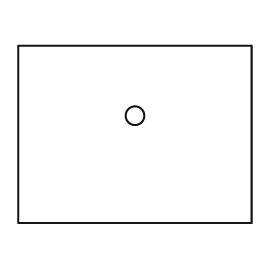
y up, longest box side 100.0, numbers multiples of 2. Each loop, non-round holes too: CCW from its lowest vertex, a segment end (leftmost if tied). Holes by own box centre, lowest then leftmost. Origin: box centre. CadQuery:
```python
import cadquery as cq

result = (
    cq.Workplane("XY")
    .moveTo(-50.0, -38.0)
    .lineTo(50.0, -38.0)
    .lineTo(50.0, 38.0)
    .lineTo(-50.0, 38.0)
    .close()
    .moveTo(0.0, 8.0)
    .circle(4.0)
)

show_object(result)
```